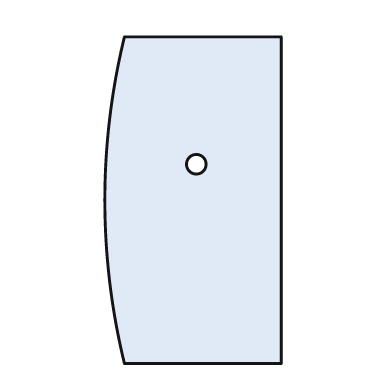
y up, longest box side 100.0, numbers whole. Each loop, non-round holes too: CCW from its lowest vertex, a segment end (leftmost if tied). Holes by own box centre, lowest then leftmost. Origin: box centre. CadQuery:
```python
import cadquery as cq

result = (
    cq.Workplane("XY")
    .moveTo(-21.0, -50.0)
    .lineTo(27.0, -50.0)
    .lineTo(27.0, 50.0)
    .lineTo(-21.0, 50.0)
    .threePointArc((-27.0, 0.0), (-21.0, -50.0))
    .close()
    .moveTo(1.0, 11.0)
    .circle(3.0)
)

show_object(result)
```